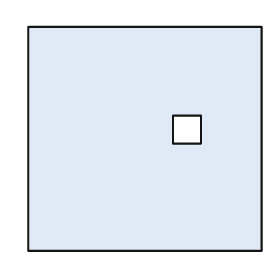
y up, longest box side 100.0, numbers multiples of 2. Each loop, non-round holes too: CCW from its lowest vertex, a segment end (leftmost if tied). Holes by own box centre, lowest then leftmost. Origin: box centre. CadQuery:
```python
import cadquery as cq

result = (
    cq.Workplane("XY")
    .moveTo(-50.0, -48.0)
    .lineTo(50.0, -48.0)
    .lineTo(50.0, 48.0)
    .lineTo(-50.0, 48.0)
    .close()
    .moveTo(12.0, -2.0)
    .lineTo(24.0, -2.0)
    .lineTo(24.0, 10.0)
    .lineTo(12.0, 10.0)
    .close()
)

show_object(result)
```